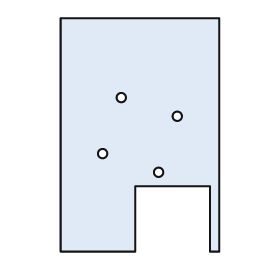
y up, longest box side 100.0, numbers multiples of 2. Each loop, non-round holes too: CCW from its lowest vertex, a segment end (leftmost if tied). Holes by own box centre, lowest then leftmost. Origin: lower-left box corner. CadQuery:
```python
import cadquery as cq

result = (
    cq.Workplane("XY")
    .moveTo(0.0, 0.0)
    .lineTo(32.0, 0.0)
    .lineTo(32.0, 28.0)
    .lineTo(64.0, 28.0)
    .lineTo(64.0, 0.0)
    .lineTo(68.0, 0.0)
    .lineTo(68.0, 100.0)
    .lineTo(0.0, 100.0)
    .close()
    .moveTo(42.0, 34.0)
    .circle(2.0)
    .moveTo(18.0, 42.0)
    .circle(2.0)
    .moveTo(50.0, 58.0)
    .circle(2.0)
    .moveTo(26.0, 66.0)
    .circle(2.0)
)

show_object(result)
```